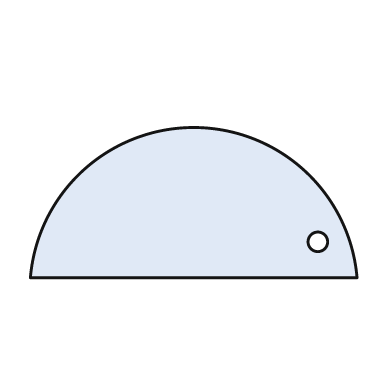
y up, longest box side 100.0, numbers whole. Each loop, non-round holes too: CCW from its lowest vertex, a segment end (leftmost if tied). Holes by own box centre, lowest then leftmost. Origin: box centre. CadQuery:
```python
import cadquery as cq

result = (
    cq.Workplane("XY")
    .moveTo(-50.0, -23.0)
    .lineTo(50.0, -23.0)
    .threePointArc((0.0, 23.0), (-50.0, -23.0))
    .close()
    .moveTo(38.0, -12.0)
    .circle(3.0)
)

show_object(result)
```